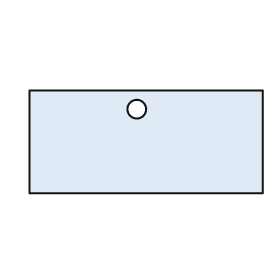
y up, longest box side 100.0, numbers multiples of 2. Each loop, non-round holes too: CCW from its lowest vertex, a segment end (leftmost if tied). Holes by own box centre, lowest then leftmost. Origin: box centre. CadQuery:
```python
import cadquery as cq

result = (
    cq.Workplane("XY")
    .moveTo(-50.0, -22.0)
    .lineTo(50.0, -22.0)
    .lineTo(50.0, 22.0)
    .lineTo(-50.0, 22.0)
    .close()
    .moveTo(-4.0, 14.0)
    .circle(4.0)
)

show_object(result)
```